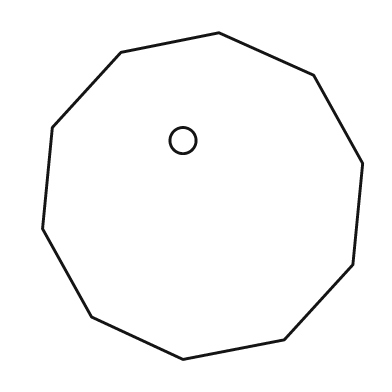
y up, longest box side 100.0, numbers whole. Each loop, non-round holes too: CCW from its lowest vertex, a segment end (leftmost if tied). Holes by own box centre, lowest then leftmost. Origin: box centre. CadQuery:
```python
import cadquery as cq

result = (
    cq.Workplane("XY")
    .moveTo(-6.0, -50.0)
    .lineTo(25.0, -44.0)
    .lineTo(46.0, -21.0)
    .lineTo(49.0, 10.0)
    .lineTo(34.0, 37.0)
    .lineTo(5.0, 50.0)
    .lineTo(-25.0, 44.0)
    .lineTo(-46.0, 21.0)
    .lineTo(-49.0, -10.0)
    .lineTo(-34.0, -37.0)
    .close()
    .moveTo(-6.0, 17.0)
    .circle(4.0)
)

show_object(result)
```